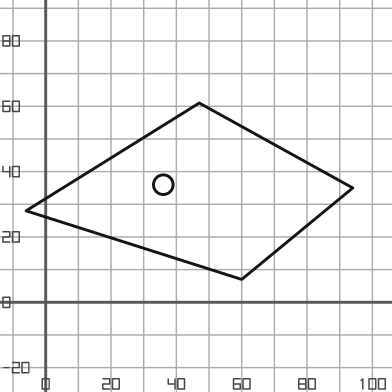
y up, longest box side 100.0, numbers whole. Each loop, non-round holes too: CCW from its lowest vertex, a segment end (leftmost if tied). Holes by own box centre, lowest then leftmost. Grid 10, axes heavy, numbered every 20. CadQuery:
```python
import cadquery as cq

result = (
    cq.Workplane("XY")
    .moveTo(60.0, 7.0)
    .lineTo(94.0, 35.0)
    .lineTo(47.0, 61.0)
    .lineTo(-6.0, 28.0)
    .close()
    .moveTo(36.0, 36.0)
    .circle(3.0)
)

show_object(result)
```